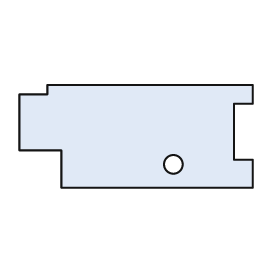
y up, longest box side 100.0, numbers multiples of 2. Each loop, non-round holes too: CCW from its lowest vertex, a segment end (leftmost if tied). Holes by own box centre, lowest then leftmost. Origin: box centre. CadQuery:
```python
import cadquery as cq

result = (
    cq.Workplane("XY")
    .moveTo(-32.0, -22.0)
    .lineTo(50.0, -22.0)
    .lineTo(50.0, -10.0)
    .lineTo(42.0, -10.0)
    .lineTo(42.0, 14.0)
    .lineTo(50.0, 14.0)
    .lineTo(50.0, 22.0)
    .lineTo(-38.0, 22.0)
    .lineTo(-38.0, 18.0)
    .lineTo(-50.0, 18.0)
    .lineTo(-50.0, -6.0)
    .lineTo(-32.0, -6.0)
    .close()
    .moveTo(16.0, -12.0)
    .circle(4.0)
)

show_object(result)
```